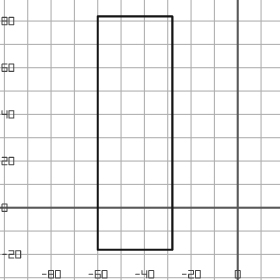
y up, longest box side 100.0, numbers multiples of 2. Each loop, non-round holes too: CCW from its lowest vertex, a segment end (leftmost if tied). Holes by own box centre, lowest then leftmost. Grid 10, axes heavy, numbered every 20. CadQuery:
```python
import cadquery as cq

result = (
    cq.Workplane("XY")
    .moveTo(-60.0, -18.0)
    .lineTo(-28.0, -18.0)
    .lineTo(-28.0, 82.0)
    .lineTo(-60.0, 82.0)
    .close()
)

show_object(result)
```